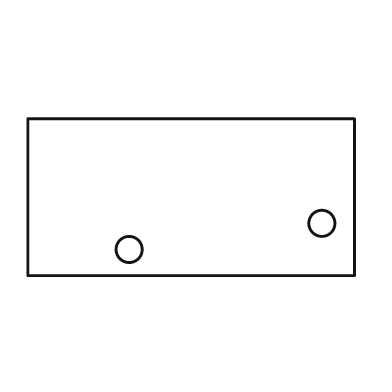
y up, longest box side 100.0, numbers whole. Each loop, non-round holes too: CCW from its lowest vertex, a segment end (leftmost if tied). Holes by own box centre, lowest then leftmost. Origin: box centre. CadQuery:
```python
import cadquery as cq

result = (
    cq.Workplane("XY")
    .moveTo(-50.0, -24.0)
    .lineTo(50.0, -24.0)
    .lineTo(50.0, 24.0)
    .lineTo(-50.0, 24.0)
    .close()
    .moveTo(-19.0, -16.0)
    .circle(4.0)
    .moveTo(40.0, -8.0)
    .circle(4.0)
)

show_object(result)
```